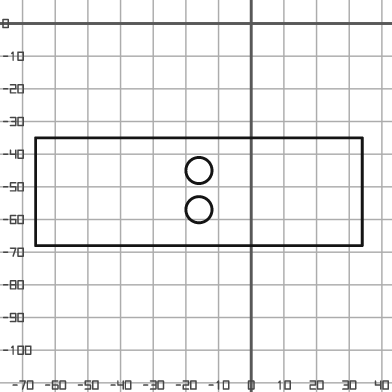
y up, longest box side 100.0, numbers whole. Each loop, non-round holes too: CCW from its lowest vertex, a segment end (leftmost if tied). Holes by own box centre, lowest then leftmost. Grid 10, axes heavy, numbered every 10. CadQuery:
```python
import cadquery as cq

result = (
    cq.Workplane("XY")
    .moveTo(-66.0, -68.0)
    .lineTo(34.0, -68.0)
    .lineTo(34.0, -35.0)
    .lineTo(-66.0, -35.0)
    .close()
    .moveTo(-16.0, -57.0)
    .circle(4.0)
    .moveTo(-16.0, -45.0)
    .circle(4.0)
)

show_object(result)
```